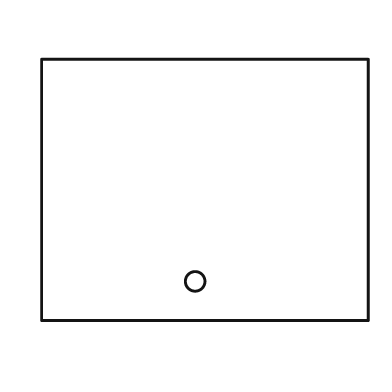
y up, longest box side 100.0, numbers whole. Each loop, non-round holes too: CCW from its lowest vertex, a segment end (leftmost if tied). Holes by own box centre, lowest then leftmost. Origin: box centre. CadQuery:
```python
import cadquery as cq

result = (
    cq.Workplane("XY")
    .moveTo(-50.0, -40.0)
    .lineTo(50.0, -40.0)
    .lineTo(50.0, 40.0)
    .lineTo(-50.0, 40.0)
    .close()
    .moveTo(-3.0, -28.0)
    .circle(3.0)
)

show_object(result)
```